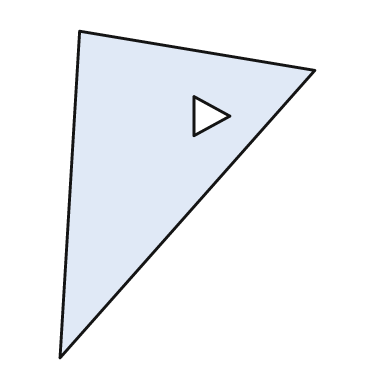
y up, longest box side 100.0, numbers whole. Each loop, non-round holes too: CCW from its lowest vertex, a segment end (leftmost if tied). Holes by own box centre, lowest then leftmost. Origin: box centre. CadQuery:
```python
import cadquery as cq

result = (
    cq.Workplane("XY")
    .moveTo(-39.0, -50.0)
    .lineTo(39.0, 38.0)
    .lineTo(-33.0, 50.0)
    .close()
    .moveTo(2.0, 18.0)
    .lineTo(13.0, 24.0)
    .lineTo(2.0, 30.0)
    .close()
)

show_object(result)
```